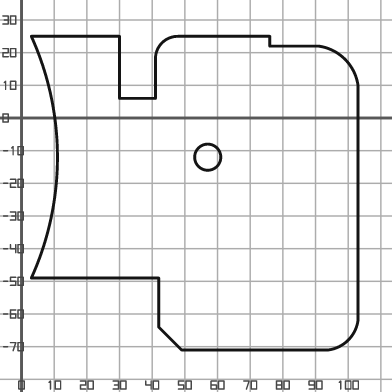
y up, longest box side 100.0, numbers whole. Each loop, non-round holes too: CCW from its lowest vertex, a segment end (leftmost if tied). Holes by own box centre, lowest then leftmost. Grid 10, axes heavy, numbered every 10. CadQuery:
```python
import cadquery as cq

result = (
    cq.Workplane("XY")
    .moveTo(49.0, -71.0)
    .lineTo(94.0, -71.0)
    .threePointArc((100.0, -68.0), (103.0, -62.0))
    .lineTo(103.0, 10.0)
    .threePointArc((99.0, 18.0), (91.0, 22.0))
    .lineTo(76.0, 22.0)
    .lineTo(76.0, 25.0)
    .lineTo(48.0, 25.0)
    .threePointArc((43.0, 23.0), (41.0, 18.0))
    .lineTo(41.0, 6.0)
    .lineTo(30.0, 6.0)
    .lineTo(30.0, 25.0)
    .lineTo(3.0, 25.0)
    .threePointArc((11.0, -12.0), (3.0, -49.0))
    .lineTo(42.0, -49.0)
    .lineTo(42.0, -64.0)
    .close()
    .moveTo(57.0, -12.0)
    .circle(4.0)
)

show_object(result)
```